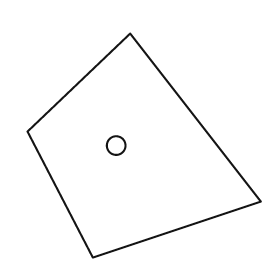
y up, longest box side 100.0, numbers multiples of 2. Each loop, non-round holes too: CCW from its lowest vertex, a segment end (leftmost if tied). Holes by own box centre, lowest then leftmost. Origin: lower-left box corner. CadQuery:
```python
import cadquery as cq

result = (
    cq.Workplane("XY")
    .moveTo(28.0, 0.0)
    .lineTo(100.0, 24.0)
    .lineTo(44.0, 96.0)
    .lineTo(0.0, 54.0)
    .close()
    .moveTo(38.0, 48.0)
    .circle(4.0)
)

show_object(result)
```